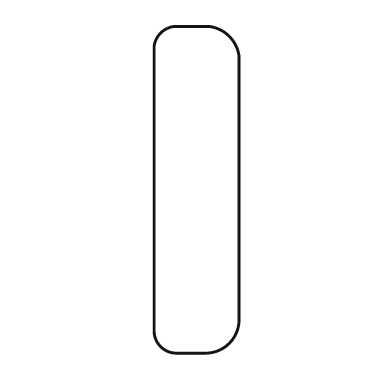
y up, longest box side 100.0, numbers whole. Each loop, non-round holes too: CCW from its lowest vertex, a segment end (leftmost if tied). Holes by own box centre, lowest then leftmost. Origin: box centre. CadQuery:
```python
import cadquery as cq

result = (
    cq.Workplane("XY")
    .moveTo(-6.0, -50.0)
    .lineTo(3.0, -50.0)
    .threePointArc((10.0, -47.0), (13.0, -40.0))
    .lineTo(13.0, 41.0)
    .threePointArc((10.0, 47.0), (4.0, 50.0))
    .lineTo(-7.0, 50.0)
    .threePointArc((-11.0, 48.0), (-13.0, 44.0))
    .lineTo(-13.0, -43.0)
    .threePointArc((-11.0, -48.0), (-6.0, -50.0))
    .close()
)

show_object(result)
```